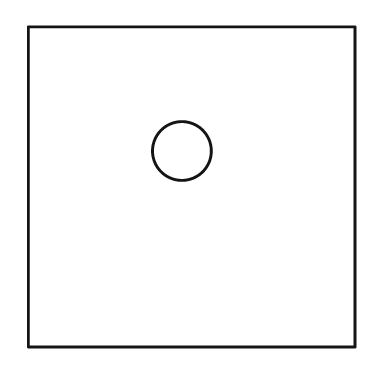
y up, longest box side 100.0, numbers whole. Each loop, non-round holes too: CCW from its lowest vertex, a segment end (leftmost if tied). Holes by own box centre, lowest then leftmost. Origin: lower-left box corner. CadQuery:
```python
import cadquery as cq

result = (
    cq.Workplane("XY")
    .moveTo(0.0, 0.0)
    .lineTo(100.0, 0.0)
    .lineTo(100.0, 98.0)
    .lineTo(0.0, 98.0)
    .close()
    .moveTo(47.0, 60.0)
    .circle(9.0)
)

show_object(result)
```